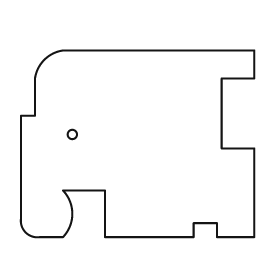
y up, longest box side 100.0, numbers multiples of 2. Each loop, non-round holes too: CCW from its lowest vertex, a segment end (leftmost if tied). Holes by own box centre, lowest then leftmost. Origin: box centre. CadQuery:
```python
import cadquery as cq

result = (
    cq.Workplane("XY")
    .moveTo(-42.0, -40.0)
    .lineTo(-32.0, -40.0)
    .threePointArc((-28.0, -30.0), (-32.0, -20.0))
    .lineTo(-14.0, -20.0)
    .lineTo(-14.0, -40.0)
    .lineTo(24.0, -40.0)
    .lineTo(24.0, -34.0)
    .lineTo(34.0, -34.0)
    .lineTo(34.0, -40.0)
    .lineTo(50.0, -40.0)
    .lineTo(50.0, -2.0)
    .lineTo(36.0, -2.0)
    .lineTo(36.0, 28.0)
    .lineTo(50.0, 28.0)
    .lineTo(50.0, 40.0)
    .lineTo(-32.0, 40.0)
    .threePointArc((-40.0, 36.0), (-44.0, 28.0))
    .lineTo(-44.0, 12.0)
    .lineTo(-50.0, 12.0)
    .lineTo(-50.0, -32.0)
    .threePointArc((-48.0, -38.0), (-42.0, -40.0))
    .close()
    .moveTo(-28.0, 4.0)
    .circle(2.0)
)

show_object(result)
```